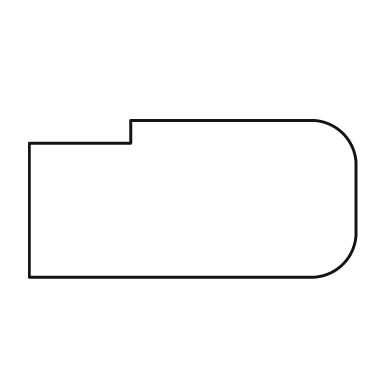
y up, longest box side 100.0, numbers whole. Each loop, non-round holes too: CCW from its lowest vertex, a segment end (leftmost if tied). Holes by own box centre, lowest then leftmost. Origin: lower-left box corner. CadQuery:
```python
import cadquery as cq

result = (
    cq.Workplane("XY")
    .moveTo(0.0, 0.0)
    .lineTo(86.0, 0.0)
    .threePointArc((96.0, 4.0), (100.0, 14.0))
    .lineTo(100.0, 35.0)
    .threePointArc((96.0, 44.0), (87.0, 48.0))
    .lineTo(31.0, 48.0)
    .lineTo(31.0, 41.0)
    .lineTo(0.0, 41.0)
    .close()
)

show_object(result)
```